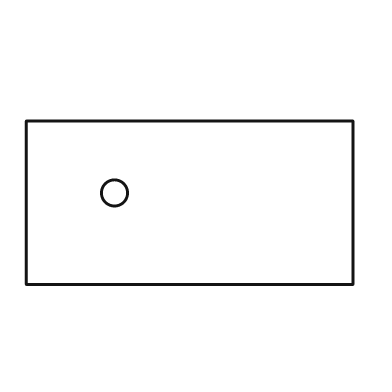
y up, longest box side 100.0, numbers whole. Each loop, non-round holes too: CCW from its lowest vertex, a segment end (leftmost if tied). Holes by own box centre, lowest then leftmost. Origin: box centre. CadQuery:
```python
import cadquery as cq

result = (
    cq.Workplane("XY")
    .moveTo(-50.0, -25.0)
    .lineTo(50.0, -25.0)
    .lineTo(50.0, 25.0)
    .lineTo(-50.0, 25.0)
    .close()
    .moveTo(-23.0, 3.0)
    .circle(4.0)
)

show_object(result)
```